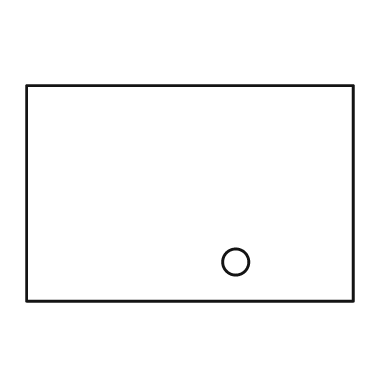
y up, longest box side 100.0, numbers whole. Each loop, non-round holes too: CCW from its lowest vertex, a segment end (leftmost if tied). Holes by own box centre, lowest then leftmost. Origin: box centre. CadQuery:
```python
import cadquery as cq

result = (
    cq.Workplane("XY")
    .moveTo(-50.0, -33.0)
    .lineTo(50.0, -33.0)
    .lineTo(50.0, 33.0)
    .lineTo(-50.0, 33.0)
    .close()
    .moveTo(14.0, -21.0)
    .circle(4.0)
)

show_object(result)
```